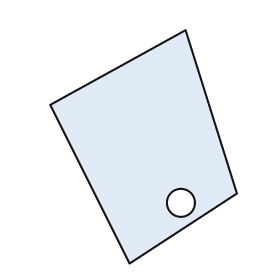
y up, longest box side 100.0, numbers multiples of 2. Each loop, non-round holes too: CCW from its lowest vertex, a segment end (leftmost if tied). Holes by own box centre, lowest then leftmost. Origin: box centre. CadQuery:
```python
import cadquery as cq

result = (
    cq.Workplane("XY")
    .moveTo(-6.0, -50.0)
    .lineTo(40.0, -20.0)
    .lineTo(18.0, 50.0)
    .lineTo(-40.0, 18.0)
    .close()
    .moveTo(16.0, -24.0)
    .circle(6.0)
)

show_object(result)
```